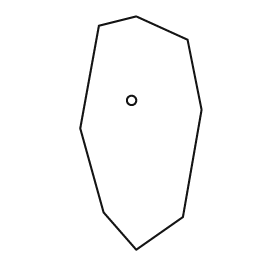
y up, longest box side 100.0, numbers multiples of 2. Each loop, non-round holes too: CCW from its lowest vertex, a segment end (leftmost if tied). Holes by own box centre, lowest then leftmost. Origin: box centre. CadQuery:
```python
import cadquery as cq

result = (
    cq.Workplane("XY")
    .moveTo(-2.0, -50.0)
    .lineTo(18.0, -36.0)
    .lineTo(26.0, 10.0)
    .lineTo(20.0, 40.0)
    .lineTo(-2.0, 50.0)
    .lineTo(-18.0, 46.0)
    .lineTo(-26.0, 2.0)
    .lineTo(-16.0, -34.0)
    .close()
    .moveTo(-4.0, 14.0)
    .circle(2.0)
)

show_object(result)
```